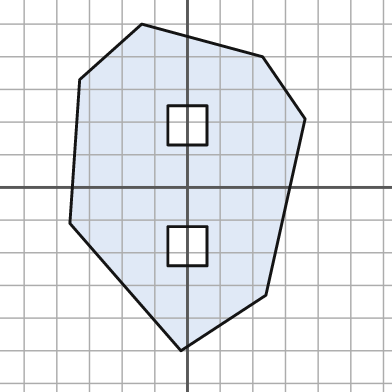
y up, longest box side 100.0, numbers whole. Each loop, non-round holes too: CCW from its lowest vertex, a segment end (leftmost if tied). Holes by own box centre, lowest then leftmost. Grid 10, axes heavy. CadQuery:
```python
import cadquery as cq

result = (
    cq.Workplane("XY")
    .moveTo(-2.0, -50.0)
    .lineTo(24.0, -33.0)
    .lineTo(36.0, 21.0)
    .lineTo(23.0, 40.0)
    .lineTo(-14.0, 50.0)
    .lineTo(-33.0, 33.0)
    .lineTo(-36.0, -11.0)
    .close()
    .moveTo(-6.0, -24.0)
    .lineTo(6.0, -24.0)
    .lineTo(6.0, -12.0)
    .lineTo(-6.0, -12.0)
    .close()
    .moveTo(-6.0, 13.0)
    .lineTo(6.0, 13.0)
    .lineTo(6.0, 25.0)
    .lineTo(-6.0, 25.0)
    .close()
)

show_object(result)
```